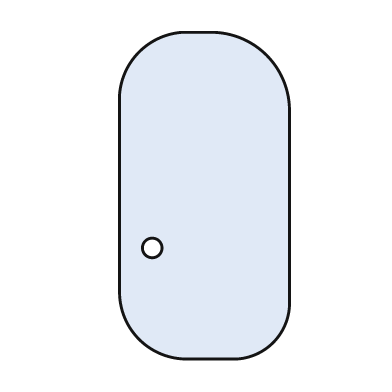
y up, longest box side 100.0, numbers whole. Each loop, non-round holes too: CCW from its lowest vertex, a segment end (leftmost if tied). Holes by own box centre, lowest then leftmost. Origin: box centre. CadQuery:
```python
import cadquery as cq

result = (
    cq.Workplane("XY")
    .moveTo(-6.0, -50.0)
    .lineTo(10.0, -50.0)
    .threePointArc((21.0, -45.0), (26.0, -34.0))
    .lineTo(26.0, 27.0)
    .threePointArc((19.0, 43.0), (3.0, 50.0))
    .lineTo(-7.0, 50.0)
    .threePointArc((-20.0, 44.0), (-26.0, 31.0))
    .lineTo(-26.0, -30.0)
    .threePointArc((-20.0, -44.0), (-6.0, -50.0))
    .close()
    .moveTo(-16.0, -16.0)
    .circle(3.0)
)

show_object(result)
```